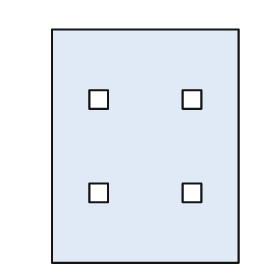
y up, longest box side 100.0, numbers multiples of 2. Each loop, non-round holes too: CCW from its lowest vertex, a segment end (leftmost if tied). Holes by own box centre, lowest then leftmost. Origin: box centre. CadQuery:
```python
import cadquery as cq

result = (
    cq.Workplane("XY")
    .moveTo(-40.0, -50.0)
    .lineTo(40.0, -50.0)
    .lineTo(40.0, 50.0)
    .lineTo(-40.0, 50.0)
    .close()
    .moveTo(-24.0, -24.0)
    .lineTo(-16.0, -24.0)
    .lineTo(-16.0, -16.0)
    .lineTo(-24.0, -16.0)
    .close()
    .moveTo(16.0, -24.0)
    .lineTo(24.0, -24.0)
    .lineTo(24.0, -16.0)
    .lineTo(16.0, -16.0)
    .close()
    .moveTo(-24.0, 16.0)
    .lineTo(-16.0, 16.0)
    .lineTo(-16.0, 24.0)
    .lineTo(-24.0, 24.0)
    .close()
    .moveTo(16.0, 16.0)
    .lineTo(24.0, 16.0)
    .lineTo(24.0, 24.0)
    .lineTo(16.0, 24.0)
    .close()
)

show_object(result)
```